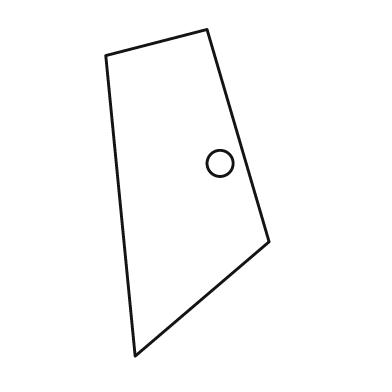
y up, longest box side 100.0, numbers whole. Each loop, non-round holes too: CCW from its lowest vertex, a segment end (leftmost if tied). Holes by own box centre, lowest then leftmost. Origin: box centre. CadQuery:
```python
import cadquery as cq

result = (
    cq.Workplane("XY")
    .moveTo(-16.0, -50.0)
    .lineTo(25.0, -15.0)
    .lineTo(6.0, 50.0)
    .lineTo(-25.0, 42.0)
    .close()
    .moveTo(10.0, 9.0)
    .circle(4.0)
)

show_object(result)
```